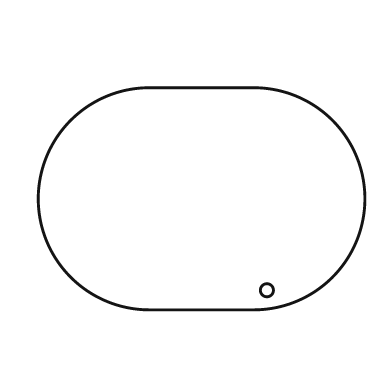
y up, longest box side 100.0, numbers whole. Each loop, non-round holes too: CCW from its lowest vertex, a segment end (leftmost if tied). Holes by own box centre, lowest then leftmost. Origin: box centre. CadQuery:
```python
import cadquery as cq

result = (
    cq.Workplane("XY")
    .moveTo(-16.0, -34.0)
    .lineTo(16.0, -34.0)
    .threePointArc((50.0, 0.0), (16.0, 34.0))
    .lineTo(-16.0, 34.0)
    .threePointArc((-50.0, 0.0), (-16.0, -34.0))
    .close()
    .moveTo(20.0, -28.0)
    .circle(2.0)
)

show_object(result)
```